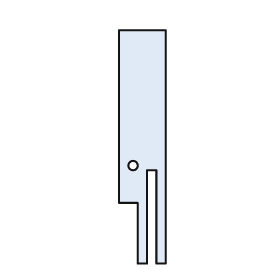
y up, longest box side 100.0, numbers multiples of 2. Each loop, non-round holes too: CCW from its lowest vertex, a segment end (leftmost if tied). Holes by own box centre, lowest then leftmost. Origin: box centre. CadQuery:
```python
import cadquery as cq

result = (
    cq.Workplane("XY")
    .moveTo(-2.0, -50.0)
    .lineTo(2.0, -50.0)
    .lineTo(2.0, -10.0)
    .lineTo(6.0, -10.0)
    .lineTo(6.0, -50.0)
    .lineTo(10.0, -50.0)
    .lineTo(10.0, 50.0)
    .lineTo(-10.0, 50.0)
    .lineTo(-10.0, -24.0)
    .lineTo(-2.0, -24.0)
    .close()
    .moveTo(-4.0, -8.0)
    .circle(2.0)
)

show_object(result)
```